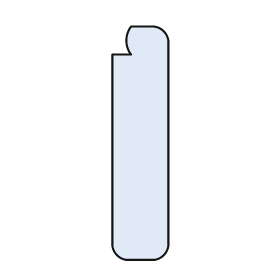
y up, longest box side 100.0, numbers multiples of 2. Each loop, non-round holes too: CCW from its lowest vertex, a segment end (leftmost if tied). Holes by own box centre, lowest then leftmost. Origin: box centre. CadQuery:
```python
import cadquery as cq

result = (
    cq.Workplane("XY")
    .moveTo(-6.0, -50.0)
    .lineTo(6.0, -50.0)
    .threePointArc((10.0, -48.0), (12.0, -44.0))
    .lineTo(12.0, 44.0)
    .threePointArc((10.0, 48.0), (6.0, 50.0))
    .lineTo(-4.0, 50.0)
    .threePointArc((-6.0, 44.0), (-4.0, 38.0))
    .lineTo(-12.0, 38.0)
    .lineTo(-12.0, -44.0)
    .threePointArc((-10.0, -48.0), (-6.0, -50.0))
    .close()
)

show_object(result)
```